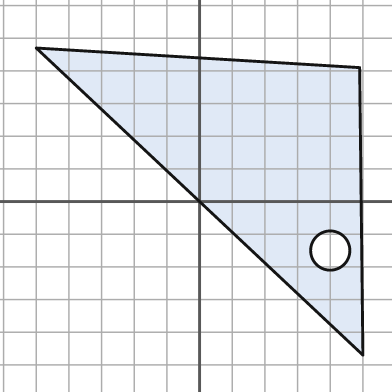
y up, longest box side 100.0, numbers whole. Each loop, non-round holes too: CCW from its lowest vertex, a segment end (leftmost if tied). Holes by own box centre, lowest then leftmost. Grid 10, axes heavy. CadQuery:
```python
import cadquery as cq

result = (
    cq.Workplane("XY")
    .moveTo(50.0, -47.0)
    .lineTo(49.0, 41.0)
    .lineTo(-50.0, 47.0)
    .close()
    .moveTo(40.0, -15.0)
    .circle(6.0)
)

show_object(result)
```